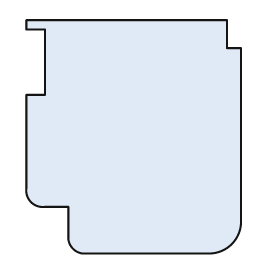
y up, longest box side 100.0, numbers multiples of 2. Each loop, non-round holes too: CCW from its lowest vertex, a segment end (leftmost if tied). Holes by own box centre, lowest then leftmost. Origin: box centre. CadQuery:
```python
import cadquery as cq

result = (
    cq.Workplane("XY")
    .moveTo(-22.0, -50.0)
    .lineTo(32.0, -50.0)
    .threePointArc((42.0, -46.0), (46.0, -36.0))
    .lineTo(46.0, 38.0)
    .lineTo(40.0, 38.0)
    .lineTo(40.0, 50.0)
    .lineTo(-46.0, 50.0)
    .lineTo(-46.0, 46.0)
    .lineTo(-38.0, 46.0)
    .lineTo(-38.0, 18.0)
    .lineTo(-46.0, 18.0)
    .lineTo(-46.0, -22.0)
    .threePointArc((-44.0, -28.0), (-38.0, -30.0))
    .lineTo(-28.0, -30.0)
    .lineTo(-28.0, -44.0)
    .threePointArc((-26.0, -48.0), (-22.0, -50.0))
    .close()
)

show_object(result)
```